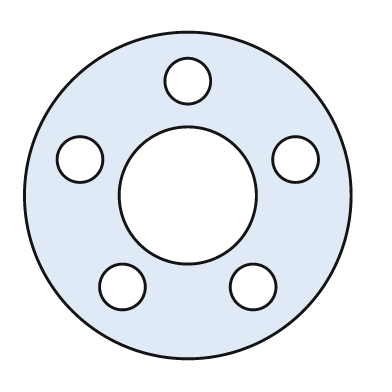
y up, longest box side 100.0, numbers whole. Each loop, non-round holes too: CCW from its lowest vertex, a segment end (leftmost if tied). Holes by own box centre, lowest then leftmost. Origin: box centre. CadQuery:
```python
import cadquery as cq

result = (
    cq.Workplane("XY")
    .moveTo(0.0, 0.0)
    .circle(50.0)
    .moveTo(-20.0, -28.0)
    .circle(7.0)
    .moveTo(20.0, -28.0)
    .circle(7.0)
    .moveTo(0.0, 0.0)
    .circle(21.0)
    .moveTo(-33.0, 11.0)
    .circle(7.0)
    .moveTo(33.0, 11.0)
    .circle(7.0)
    .moveTo(0.0, 35.0)
    .circle(7.0)
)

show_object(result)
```